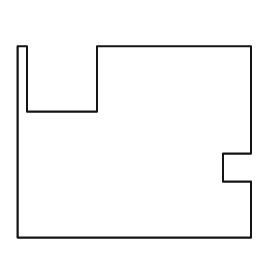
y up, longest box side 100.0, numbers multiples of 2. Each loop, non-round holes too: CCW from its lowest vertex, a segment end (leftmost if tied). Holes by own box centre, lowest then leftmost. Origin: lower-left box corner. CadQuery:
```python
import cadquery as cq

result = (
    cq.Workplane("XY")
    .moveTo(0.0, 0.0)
    .lineTo(100.0, 0.0)
    .lineTo(100.0, 24.0)
    .lineTo(88.0, 24.0)
    .lineTo(88.0, 36.0)
    .lineTo(100.0, 36.0)
    .lineTo(100.0, 82.0)
    .lineTo(34.0, 82.0)
    .lineTo(34.0, 54.0)
    .lineTo(4.0, 54.0)
    .lineTo(4.0, 82.0)
    .lineTo(0.0, 82.0)
    .close()
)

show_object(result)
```